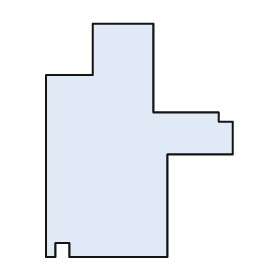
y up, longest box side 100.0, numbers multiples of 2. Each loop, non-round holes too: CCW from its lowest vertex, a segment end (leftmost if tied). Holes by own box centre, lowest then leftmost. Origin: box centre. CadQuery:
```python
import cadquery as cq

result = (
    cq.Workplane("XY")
    .moveTo(-40.0, -50.0)
    .lineTo(-36.0, -50.0)
    .lineTo(-36.0, -44.0)
    .lineTo(-30.0, -44.0)
    .lineTo(-30.0, -50.0)
    .lineTo(12.0, -50.0)
    .lineTo(12.0, -6.0)
    .lineTo(40.0, -6.0)
    .lineTo(40.0, 8.0)
    .lineTo(34.0, 8.0)
    .lineTo(34.0, 12.0)
    .lineTo(6.0, 12.0)
    .lineTo(6.0, 50.0)
    .lineTo(-20.0, 50.0)
    .lineTo(-20.0, 28.0)
    .lineTo(-40.0, 28.0)
    .close()
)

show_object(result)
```